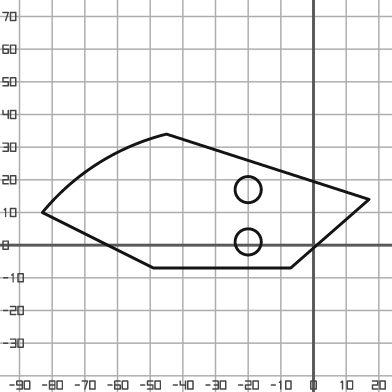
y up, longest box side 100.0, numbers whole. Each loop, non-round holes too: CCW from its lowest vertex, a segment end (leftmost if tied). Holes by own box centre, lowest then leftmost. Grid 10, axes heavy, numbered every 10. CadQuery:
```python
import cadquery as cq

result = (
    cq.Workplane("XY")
    .moveTo(-49.0, -7.0)
    .lineTo(-7.0, -7.0)
    .lineTo(17.0, 14.0)
    .lineTo(-45.0, 34.0)
    .threePointArc((-66.0, 25.0), (-83.0, 10.0))
    .close()
    .moveTo(-20.0, 1.0)
    .circle(4.0)
    .moveTo(-20.0, 17.0)
    .circle(4.0)
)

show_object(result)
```